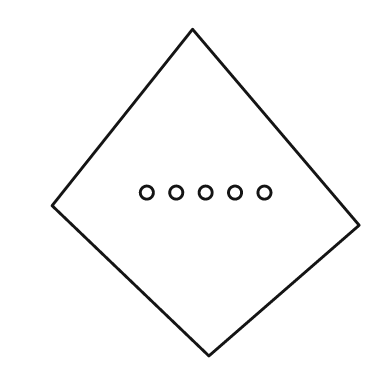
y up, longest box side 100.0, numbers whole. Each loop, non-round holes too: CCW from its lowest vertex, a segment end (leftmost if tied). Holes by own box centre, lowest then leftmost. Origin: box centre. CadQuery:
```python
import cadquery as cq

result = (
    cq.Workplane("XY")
    .moveTo(1.0, -50.0)
    .lineTo(47.0, -10.0)
    .lineTo(-4.0, 50.0)
    .lineTo(-47.0, -4.0)
    .close()
    .moveTo(-18.0, 0.0)
    .circle(2.0)
    .moveTo(-9.0, 0.0)
    .circle(2.0)
    .moveTo(0.0, 0.0)
    .circle(2.0)
    .moveTo(9.0, 0.0)
    .circle(2.0)
    .moveTo(18.0, 0.0)
    .circle(2.0)
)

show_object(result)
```